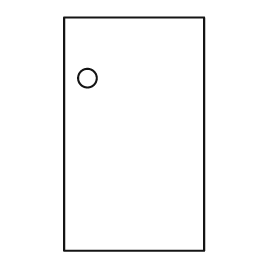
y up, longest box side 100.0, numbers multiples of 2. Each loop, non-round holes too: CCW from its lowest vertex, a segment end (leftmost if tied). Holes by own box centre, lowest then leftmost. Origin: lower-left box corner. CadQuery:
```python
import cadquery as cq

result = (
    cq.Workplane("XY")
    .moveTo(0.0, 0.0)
    .lineTo(60.0, 0.0)
    .lineTo(60.0, 100.0)
    .lineTo(0.0, 100.0)
    .close()
    .moveTo(10.0, 74.0)
    .circle(4.0)
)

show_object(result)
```